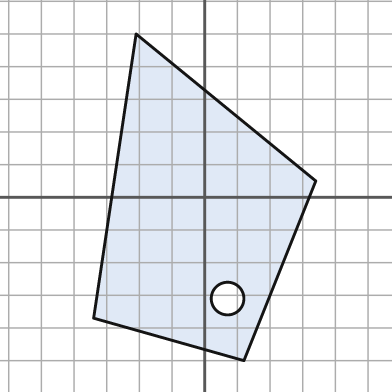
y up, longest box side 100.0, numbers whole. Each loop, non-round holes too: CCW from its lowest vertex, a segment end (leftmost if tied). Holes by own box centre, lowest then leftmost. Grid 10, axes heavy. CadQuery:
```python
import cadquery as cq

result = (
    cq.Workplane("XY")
    .moveTo(12.0, -50.0)
    .lineTo(34.0, 5.0)
    .lineTo(-21.0, 50.0)
    .lineTo(-34.0, -37.0)
    .close()
    .moveTo(7.0, -31.0)
    .circle(5.0)
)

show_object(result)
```